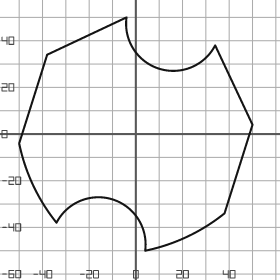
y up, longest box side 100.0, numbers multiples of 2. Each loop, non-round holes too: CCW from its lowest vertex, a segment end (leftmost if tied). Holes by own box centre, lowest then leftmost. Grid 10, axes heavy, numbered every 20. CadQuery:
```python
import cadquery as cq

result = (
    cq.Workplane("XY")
    .moveTo(4.0, -50.0)
    .threePointArc((22.0, -44.0), (38.0, -34.0))
    .lineTo(50.0, 4.0)
    .lineTo(34.0, 38.0)
    .threePointArc((10.0, 28.0), (-4.0, 50.0))
    .lineTo(-38.0, 34.0)
    .lineTo(-50.0, -4.0)
    .threePointArc((-44.0, -22.0), (-34.0, -38.0))
    .threePointArc((-10.0, -28.0), (4.0, -50.0))
    .close()
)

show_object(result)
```